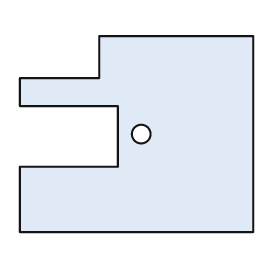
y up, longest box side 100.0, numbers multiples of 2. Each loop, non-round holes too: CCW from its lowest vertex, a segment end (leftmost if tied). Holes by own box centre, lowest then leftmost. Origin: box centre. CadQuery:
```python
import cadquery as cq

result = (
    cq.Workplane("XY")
    .moveTo(-50.0, -42.0)
    .lineTo(50.0, -42.0)
    .lineTo(50.0, 42.0)
    .lineTo(-16.0, 42.0)
    .lineTo(-16.0, 24.0)
    .lineTo(-50.0, 24.0)
    .lineTo(-50.0, 12.0)
    .lineTo(-8.0, 12.0)
    .lineTo(-8.0, -14.0)
    .lineTo(-50.0, -14.0)
    .close()
    .moveTo(2.0, 0.0)
    .circle(4.0)
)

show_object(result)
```